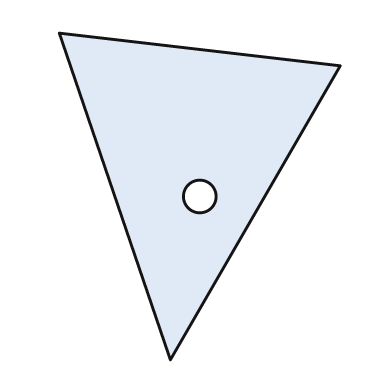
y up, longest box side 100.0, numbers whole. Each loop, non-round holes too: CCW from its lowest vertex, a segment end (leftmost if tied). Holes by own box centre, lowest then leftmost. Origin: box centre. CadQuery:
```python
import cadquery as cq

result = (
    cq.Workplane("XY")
    .moveTo(-9.0, -50.0)
    .lineTo(43.0, 40.0)
    .lineTo(-43.0, 50.0)
    .close()
    .moveTo(0.0, 0.0)
    .circle(5.0)
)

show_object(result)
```